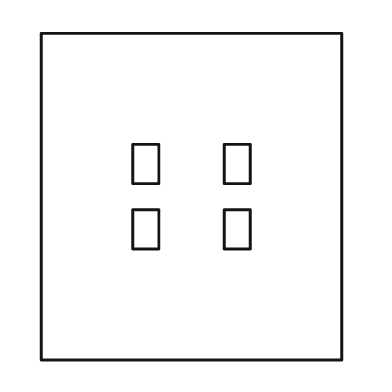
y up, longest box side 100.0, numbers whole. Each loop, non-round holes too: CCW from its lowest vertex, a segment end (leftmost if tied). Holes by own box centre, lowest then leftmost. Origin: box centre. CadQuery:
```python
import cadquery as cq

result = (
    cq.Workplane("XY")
    .moveTo(-46.0, -50.0)
    .lineTo(46.0, -50.0)
    .lineTo(46.0, 50.0)
    .lineTo(-46.0, 50.0)
    .close()
    .moveTo(-18.0, -16.0)
    .lineTo(-10.0, -16.0)
    .lineTo(-10.0, -4.0)
    .lineTo(-18.0, -4.0)
    .close()
    .moveTo(10.0, -16.0)
    .lineTo(18.0, -16.0)
    .lineTo(18.0, -4.0)
    .lineTo(10.0, -4.0)
    .close()
    .moveTo(-18.0, 4.0)
    .lineTo(-10.0, 4.0)
    .lineTo(-10.0, 16.0)
    .lineTo(-18.0, 16.0)
    .close()
    .moveTo(10.0, 4.0)
    .lineTo(18.0, 4.0)
    .lineTo(18.0, 16.0)
    .lineTo(10.0, 16.0)
    .close()
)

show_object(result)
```